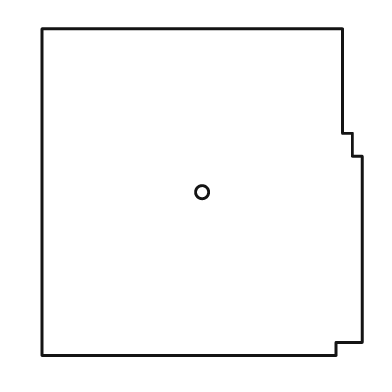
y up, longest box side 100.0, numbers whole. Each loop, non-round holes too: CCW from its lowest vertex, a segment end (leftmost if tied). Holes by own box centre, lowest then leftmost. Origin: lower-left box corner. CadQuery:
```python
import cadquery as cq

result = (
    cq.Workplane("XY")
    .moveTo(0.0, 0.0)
    .lineTo(90.0, 0.0)
    .lineTo(90.0, 4.0)
    .lineTo(98.0, 4.0)
    .lineTo(98.0, 61.0)
    .lineTo(95.0, 61.0)
    .lineTo(95.0, 68.0)
    .lineTo(92.0, 68.0)
    .lineTo(92.0, 100.0)
    .lineTo(0.0, 100.0)
    .close()
    .moveTo(49.0, 50.0)
    .circle(2.0)
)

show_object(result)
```